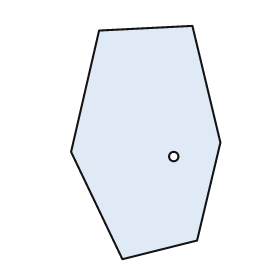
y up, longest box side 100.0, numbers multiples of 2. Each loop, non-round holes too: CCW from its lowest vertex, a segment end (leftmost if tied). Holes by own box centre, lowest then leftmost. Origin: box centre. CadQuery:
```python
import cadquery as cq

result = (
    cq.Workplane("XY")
    .moveTo(-10.0, -50.0)
    .lineTo(22.0, -42.0)
    .lineTo(32.0, 0.0)
    .lineTo(20.0, 50.0)
    .lineTo(-20.0, 48.0)
    .lineTo(-32.0, -4.0)
    .close()
    .moveTo(12.0, -6.0)
    .circle(2.0)
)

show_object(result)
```